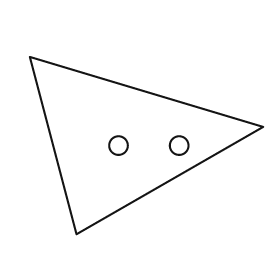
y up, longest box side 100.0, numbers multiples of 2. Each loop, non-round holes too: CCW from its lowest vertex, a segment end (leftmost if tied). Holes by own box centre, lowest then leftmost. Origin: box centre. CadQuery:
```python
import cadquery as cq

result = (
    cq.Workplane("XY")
    .moveTo(-30.0, -38.0)
    .lineTo(50.0, 8.0)
    .lineTo(-50.0, 38.0)
    .close()
    .moveTo(-12.0, 0.0)
    .circle(4.0)
    .moveTo(14.0, 0.0)
    .circle(4.0)
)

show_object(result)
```